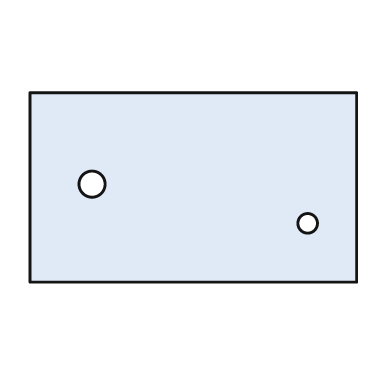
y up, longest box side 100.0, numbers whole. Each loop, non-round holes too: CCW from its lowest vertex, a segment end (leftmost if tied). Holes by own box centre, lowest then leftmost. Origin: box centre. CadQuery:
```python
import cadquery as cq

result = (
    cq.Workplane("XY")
    .moveTo(-50.0, -29.0)
    .lineTo(50.0, -29.0)
    .lineTo(50.0, 29.0)
    .lineTo(-50.0, 29.0)
    .close()
    .moveTo(35.0, -11.0)
    .circle(3.0)
    .moveTo(-31.0, 1.0)
    .circle(4.0)
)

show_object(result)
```